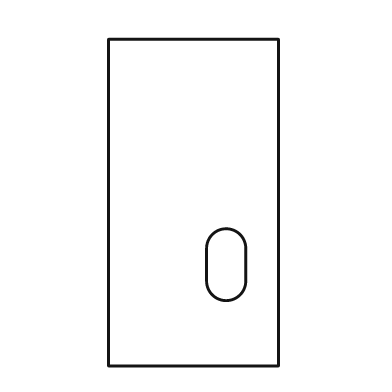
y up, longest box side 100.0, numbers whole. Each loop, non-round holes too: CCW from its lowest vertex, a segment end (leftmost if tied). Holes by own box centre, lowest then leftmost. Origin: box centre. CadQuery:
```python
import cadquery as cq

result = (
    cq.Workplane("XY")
    .moveTo(-26.0, -50.0)
    .lineTo(26.0, -50.0)
    .lineTo(26.0, 50.0)
    .lineTo(-26.0, 50.0)
    .close()
    .moveTo(4.0, -24.0)
    .threePointArc((10.0, -30.0), (16.0, -24.0))
    .lineTo(16.0, -14.0)
    .threePointArc((10.0, -8.0), (4.0, -14.0))
    .close()
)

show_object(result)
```